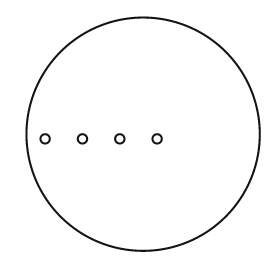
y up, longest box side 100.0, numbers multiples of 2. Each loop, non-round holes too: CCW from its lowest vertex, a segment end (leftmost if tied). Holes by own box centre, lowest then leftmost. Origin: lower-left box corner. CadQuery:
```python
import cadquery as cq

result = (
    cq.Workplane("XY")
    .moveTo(50.0, 50.0)
    .circle(50.0)
    .moveTo(8.0, 48.0)
    .circle(2.0)
    .moveTo(24.0, 48.0)
    .circle(2.0)
    .moveTo(40.0, 48.0)
    .circle(2.0)
    .moveTo(56.0, 48.0)
    .circle(2.0)
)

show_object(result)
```